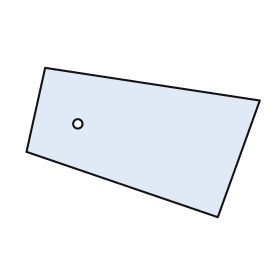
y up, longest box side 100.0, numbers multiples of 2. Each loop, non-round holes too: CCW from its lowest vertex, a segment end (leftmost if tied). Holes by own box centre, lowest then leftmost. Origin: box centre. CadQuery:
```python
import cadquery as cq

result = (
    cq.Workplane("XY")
    .moveTo(32.0, -32.0)
    .lineTo(50.0, 18.0)
    .lineTo(-42.0, 32.0)
    .lineTo(-50.0, -4.0)
    .close()
    .moveTo(-28.0, 8.0)
    .circle(2.0)
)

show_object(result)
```